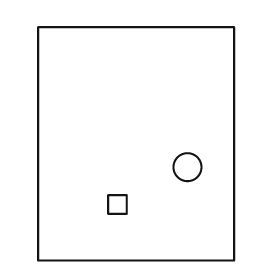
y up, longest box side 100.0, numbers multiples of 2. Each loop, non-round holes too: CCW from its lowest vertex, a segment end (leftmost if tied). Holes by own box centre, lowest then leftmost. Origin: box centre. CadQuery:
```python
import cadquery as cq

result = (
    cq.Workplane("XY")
    .moveTo(-42.0, -50.0)
    .lineTo(42.0, -50.0)
    .lineTo(42.0, 50.0)
    .lineTo(-42.0, 50.0)
    .close()
    .moveTo(-12.0, -30.0)
    .lineTo(-4.0, -30.0)
    .lineTo(-4.0, -22.0)
    .lineTo(-12.0, -22.0)
    .close()
    .moveTo(22.0, -10.0)
    .circle(6.0)
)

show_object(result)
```